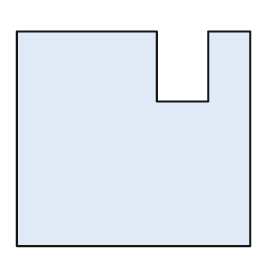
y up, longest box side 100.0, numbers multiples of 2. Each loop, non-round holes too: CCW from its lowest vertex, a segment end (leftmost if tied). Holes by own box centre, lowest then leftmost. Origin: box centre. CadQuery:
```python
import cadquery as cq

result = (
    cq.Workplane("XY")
    .moveTo(-50.0, -46.0)
    .lineTo(50.0, -46.0)
    .lineTo(50.0, 46.0)
    .lineTo(32.0, 46.0)
    .lineTo(32.0, 16.0)
    .lineTo(10.0, 16.0)
    .lineTo(10.0, 46.0)
    .lineTo(-50.0, 46.0)
    .close()
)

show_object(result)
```